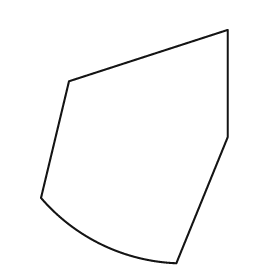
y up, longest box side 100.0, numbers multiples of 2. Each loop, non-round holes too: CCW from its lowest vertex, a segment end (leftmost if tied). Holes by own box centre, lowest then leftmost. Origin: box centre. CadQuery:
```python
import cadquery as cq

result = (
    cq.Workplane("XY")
    .moveTo(18.0, -50.0)
    .lineTo(40.0, 4.0)
    .lineTo(40.0, 50.0)
    .lineTo(-28.0, 28.0)
    .lineTo(-40.0, -22.0)
    .threePointArc((-14.0, -42.0), (18.0, -50.0))
    .close()
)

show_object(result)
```